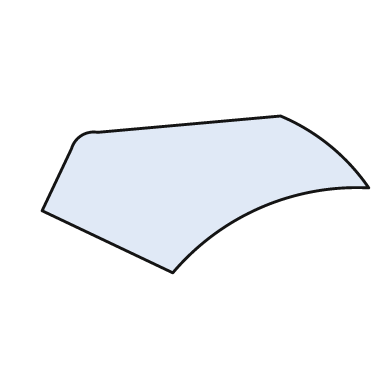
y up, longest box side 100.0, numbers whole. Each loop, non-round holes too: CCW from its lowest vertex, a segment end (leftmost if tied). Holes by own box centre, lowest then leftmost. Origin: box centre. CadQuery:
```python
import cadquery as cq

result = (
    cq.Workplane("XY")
    .moveTo(-10.0, -24.0)
    .threePointArc((17.0, -4.0), (50.0, 2.0))
    .threePointArc((38.0, 15.0), (23.0, 24.0))
    .lineTo(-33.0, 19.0)
    .threePointArc((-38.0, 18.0), (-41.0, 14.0))
    .lineTo(-50.0, -5.0)
    .close()
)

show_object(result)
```